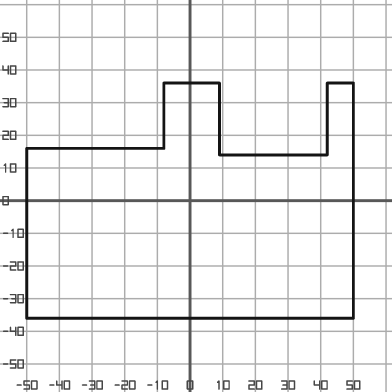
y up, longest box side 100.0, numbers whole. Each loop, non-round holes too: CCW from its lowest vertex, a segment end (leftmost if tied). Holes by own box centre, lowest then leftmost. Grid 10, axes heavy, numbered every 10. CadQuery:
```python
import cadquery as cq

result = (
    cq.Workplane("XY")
    .moveTo(-50.0, -36.0)
    .lineTo(50.0, -36.0)
    .lineTo(50.0, 36.0)
    .lineTo(42.0, 36.0)
    .lineTo(42.0, 14.0)
    .lineTo(9.0, 14.0)
    .lineTo(9.0, 36.0)
    .lineTo(-8.0, 36.0)
    .lineTo(-8.0, 16.0)
    .lineTo(-50.0, 16.0)
    .close()
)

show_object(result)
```